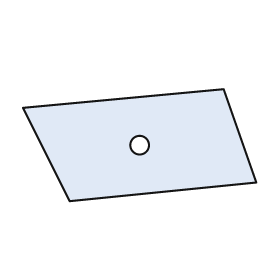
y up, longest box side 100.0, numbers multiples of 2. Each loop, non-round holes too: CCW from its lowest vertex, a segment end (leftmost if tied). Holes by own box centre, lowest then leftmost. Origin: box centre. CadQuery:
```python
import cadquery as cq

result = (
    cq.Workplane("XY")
    .moveTo(-30.0, -24.0)
    .lineTo(50.0, -16.0)
    .lineTo(36.0, 24.0)
    .lineTo(-50.0, 16.0)
    .close()
    .moveTo(0.0, 0.0)
    .circle(4.0)
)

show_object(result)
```